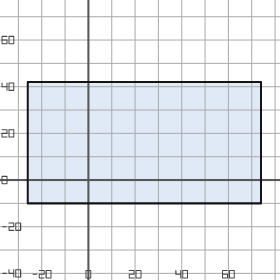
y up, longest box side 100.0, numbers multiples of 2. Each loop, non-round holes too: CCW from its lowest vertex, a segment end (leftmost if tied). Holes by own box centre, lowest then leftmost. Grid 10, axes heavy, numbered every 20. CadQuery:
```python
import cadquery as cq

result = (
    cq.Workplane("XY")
    .moveTo(-26.0, -10.0)
    .lineTo(74.0, -10.0)
    .lineTo(74.0, 42.0)
    .lineTo(-26.0, 42.0)
    .close()
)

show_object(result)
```